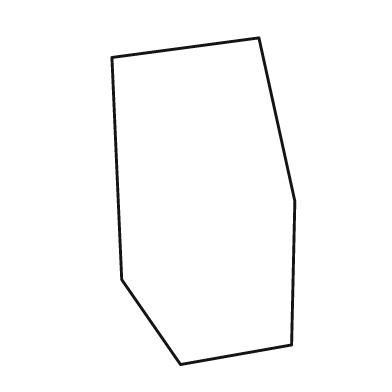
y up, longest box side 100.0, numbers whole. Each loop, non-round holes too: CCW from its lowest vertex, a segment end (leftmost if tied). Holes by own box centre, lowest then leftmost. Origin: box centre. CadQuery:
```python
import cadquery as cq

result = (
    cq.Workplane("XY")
    .moveTo(-7.0, -50.0)
    .lineTo(27.0, -44.0)
    .lineTo(28.0, 0.0)
    .lineTo(17.0, 50.0)
    .lineTo(-28.0, 44.0)
    .lineTo(-25.0, -24.0)
    .close()
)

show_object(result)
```